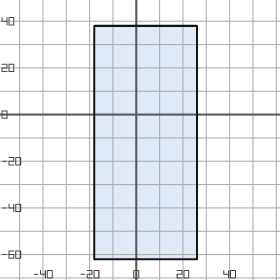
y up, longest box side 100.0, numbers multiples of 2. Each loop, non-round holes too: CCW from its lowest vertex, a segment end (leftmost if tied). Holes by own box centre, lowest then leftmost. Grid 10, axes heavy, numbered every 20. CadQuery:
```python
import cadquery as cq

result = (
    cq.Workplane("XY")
    .moveTo(-18.0, -62.0)
    .lineTo(26.0, -62.0)
    .lineTo(26.0, 38.0)
    .lineTo(-18.0, 38.0)
    .close()
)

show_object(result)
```